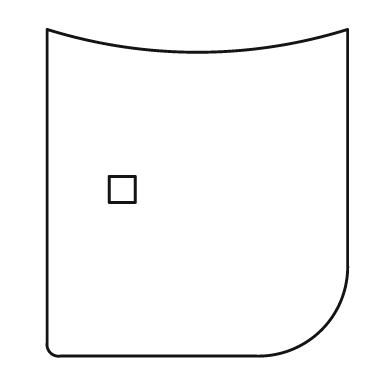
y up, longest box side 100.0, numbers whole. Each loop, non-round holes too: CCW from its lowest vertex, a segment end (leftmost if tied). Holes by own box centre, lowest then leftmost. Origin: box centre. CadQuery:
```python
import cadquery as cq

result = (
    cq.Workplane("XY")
    .moveTo(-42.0, -50.0)
    .lineTo(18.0, -50.0)
    .threePointArc((38.0, -42.0), (46.0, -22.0))
    .lineTo(46.0, 50.0)
    .threePointArc((0.0, 43.0), (-46.0, 50.0))
    .lineTo(-46.0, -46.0)
    .threePointArc((-45.0, -49.0), (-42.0, -50.0))
    .close()
    .moveTo(-27.0, -3.0)
    .lineTo(-19.0, -3.0)
    .lineTo(-19.0, 5.0)
    .lineTo(-27.0, 5.0)
    .close()
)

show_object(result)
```